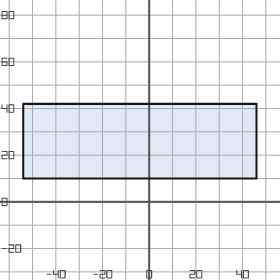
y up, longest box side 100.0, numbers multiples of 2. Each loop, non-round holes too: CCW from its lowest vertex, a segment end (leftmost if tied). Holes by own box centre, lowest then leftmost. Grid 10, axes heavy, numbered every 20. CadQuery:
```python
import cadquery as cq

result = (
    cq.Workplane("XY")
    .moveTo(-54.0, 10.0)
    .lineTo(46.0, 10.0)
    .lineTo(46.0, 42.0)
    .lineTo(-54.0, 42.0)
    .close()
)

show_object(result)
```